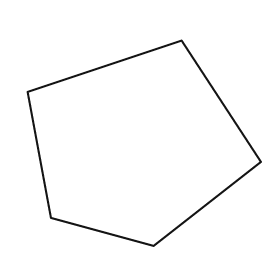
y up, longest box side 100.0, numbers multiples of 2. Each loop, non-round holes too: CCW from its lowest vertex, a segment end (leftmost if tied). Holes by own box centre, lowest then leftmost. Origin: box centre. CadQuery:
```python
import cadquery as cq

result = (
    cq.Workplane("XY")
    .moveTo(4.0, -44.0)
    .lineTo(50.0, -8.0)
    .lineTo(16.0, 44.0)
    .lineTo(-50.0, 22.0)
    .lineTo(-40.0, -32.0)
    .close()
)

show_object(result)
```